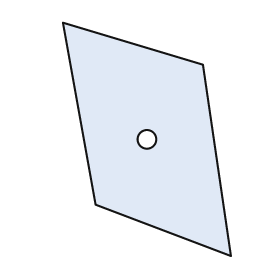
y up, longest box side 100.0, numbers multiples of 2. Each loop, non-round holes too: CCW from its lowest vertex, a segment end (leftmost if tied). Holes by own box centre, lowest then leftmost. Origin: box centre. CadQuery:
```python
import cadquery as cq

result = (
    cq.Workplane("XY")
    .moveTo(36.0, -50.0)
    .lineTo(24.0, 32.0)
    .lineTo(-36.0, 50.0)
    .lineTo(-22.0, -28.0)
    .close()
    .moveTo(0.0, 0.0)
    .circle(4.0)
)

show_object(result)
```